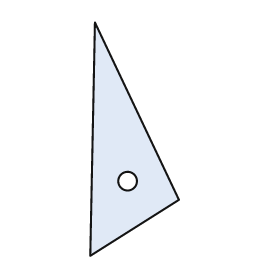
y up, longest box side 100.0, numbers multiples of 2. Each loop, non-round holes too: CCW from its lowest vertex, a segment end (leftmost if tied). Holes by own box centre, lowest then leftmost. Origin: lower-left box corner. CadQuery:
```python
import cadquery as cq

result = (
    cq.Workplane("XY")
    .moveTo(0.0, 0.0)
    .lineTo(38.0, 24.0)
    .lineTo(2.0, 100.0)
    .close()
    .moveTo(16.0, 32.0)
    .circle(4.0)
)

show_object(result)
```